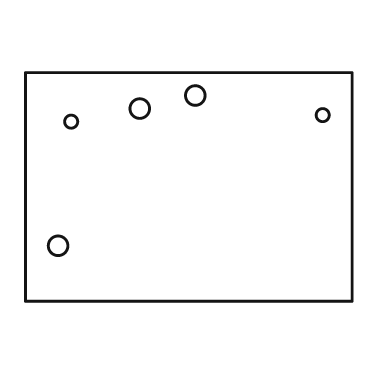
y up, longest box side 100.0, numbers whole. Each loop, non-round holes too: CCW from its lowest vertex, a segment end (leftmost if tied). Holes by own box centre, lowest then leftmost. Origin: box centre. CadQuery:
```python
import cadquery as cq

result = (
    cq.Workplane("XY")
    .moveTo(-50.0, -35.0)
    .lineTo(50.0, -35.0)
    .lineTo(50.0, 35.0)
    .lineTo(-50.0, 35.0)
    .close()
    .moveTo(-40.0, -18.0)
    .circle(3.0)
    .moveTo(-36.0, 20.0)
    .circle(2.0)
    .moveTo(41.0, 22.0)
    .circle(2.0)
    .moveTo(-15.0, 24.0)
    .circle(3.0)
    .moveTo(2.0, 28.0)
    .circle(3.0)
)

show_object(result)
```